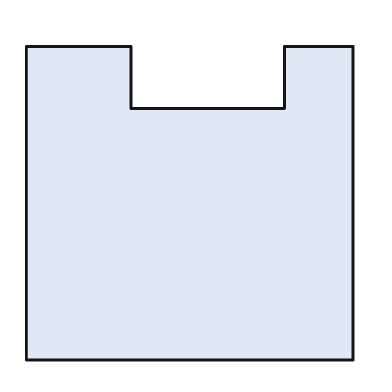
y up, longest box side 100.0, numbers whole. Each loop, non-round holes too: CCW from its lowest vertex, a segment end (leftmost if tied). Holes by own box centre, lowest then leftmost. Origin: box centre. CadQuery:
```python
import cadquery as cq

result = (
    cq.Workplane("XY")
    .moveTo(-50.0, -48.0)
    .lineTo(50.0, -48.0)
    .lineTo(50.0, 48.0)
    .lineTo(29.0, 48.0)
    .lineTo(29.0, 29.0)
    .lineTo(-18.0, 29.0)
    .lineTo(-18.0, 48.0)
    .lineTo(-50.0, 48.0)
    .close()
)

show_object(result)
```